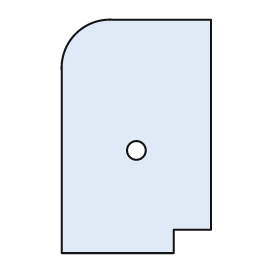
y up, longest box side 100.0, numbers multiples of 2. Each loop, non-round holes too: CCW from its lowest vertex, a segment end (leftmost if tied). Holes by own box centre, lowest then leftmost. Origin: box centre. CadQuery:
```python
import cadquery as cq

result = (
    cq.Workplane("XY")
    .moveTo(-32.0, -50.0)
    .lineTo(16.0, -50.0)
    .lineTo(16.0, -40.0)
    .lineTo(32.0, -40.0)
    .lineTo(32.0, 50.0)
    .lineTo(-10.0, 50.0)
    .threePointArc((-26.0, 44.0), (-32.0, 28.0))
    .close()
    .moveTo(0.0, -6.0)
    .circle(4.0)
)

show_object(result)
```